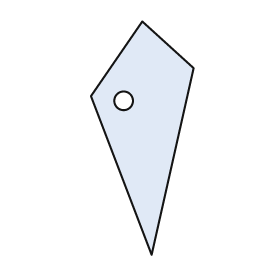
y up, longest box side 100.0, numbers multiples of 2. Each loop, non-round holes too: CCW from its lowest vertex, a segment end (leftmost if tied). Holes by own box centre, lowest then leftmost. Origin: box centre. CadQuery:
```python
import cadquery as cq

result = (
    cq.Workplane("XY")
    .moveTo(4.0, -50.0)
    .lineTo(22.0, 30.0)
    .lineTo(0.0, 50.0)
    .lineTo(-22.0, 18.0)
    .close()
    .moveTo(-8.0, 16.0)
    .circle(4.0)
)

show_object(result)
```